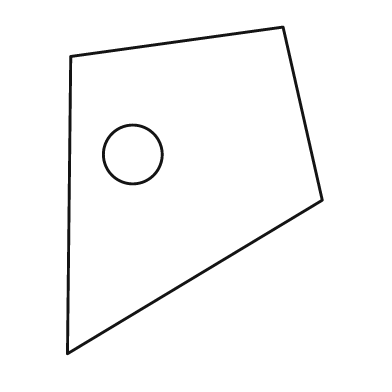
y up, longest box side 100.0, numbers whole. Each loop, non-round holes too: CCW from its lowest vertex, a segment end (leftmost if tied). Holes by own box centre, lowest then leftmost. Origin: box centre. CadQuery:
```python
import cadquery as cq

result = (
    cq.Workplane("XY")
    .moveTo(-39.0, -50.0)
    .lineTo(39.0, -3.0)
    .lineTo(27.0, 50.0)
    .lineTo(-38.0, 41.0)
    .close()
    .moveTo(-19.0, 11.0)
    .circle(9.0)
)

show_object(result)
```